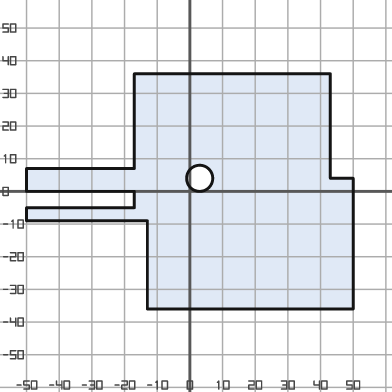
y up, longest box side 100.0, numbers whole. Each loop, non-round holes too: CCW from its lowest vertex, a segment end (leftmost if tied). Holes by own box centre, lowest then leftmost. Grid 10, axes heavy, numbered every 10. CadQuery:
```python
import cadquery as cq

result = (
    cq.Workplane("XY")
    .moveTo(-13.0, -36.0)
    .lineTo(50.0, -36.0)
    .lineTo(50.0, 4.0)
    .lineTo(43.0, 4.0)
    .lineTo(43.0, 36.0)
    .lineTo(-17.0, 36.0)
    .lineTo(-17.0, 7.0)
    .lineTo(-50.0, 7.0)
    .lineTo(-50.0, 0.0)
    .lineTo(-17.0, 0.0)
    .lineTo(-17.0, -5.0)
    .lineTo(-50.0, -5.0)
    .lineTo(-50.0, -9.0)
    .lineTo(-13.0, -9.0)
    .close()
    .moveTo(3.0, 4.0)
    .circle(4.0)
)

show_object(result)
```